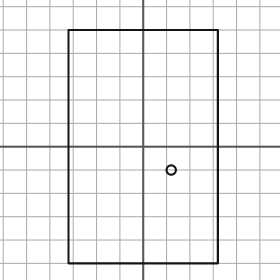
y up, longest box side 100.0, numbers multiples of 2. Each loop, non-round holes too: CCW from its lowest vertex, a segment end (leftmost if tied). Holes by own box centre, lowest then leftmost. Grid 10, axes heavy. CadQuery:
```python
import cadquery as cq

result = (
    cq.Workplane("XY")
    .moveTo(-32.0, -50.0)
    .lineTo(32.0, -50.0)
    .lineTo(32.0, 50.0)
    .lineTo(-32.0, 50.0)
    .close()
    .moveTo(12.0, -10.0)
    .circle(2.0)
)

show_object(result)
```